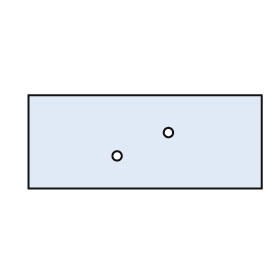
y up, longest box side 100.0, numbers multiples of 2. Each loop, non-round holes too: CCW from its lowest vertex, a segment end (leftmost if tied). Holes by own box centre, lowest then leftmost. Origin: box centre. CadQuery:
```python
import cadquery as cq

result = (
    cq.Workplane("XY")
    .moveTo(-50.0, -20.0)
    .lineTo(50.0, -20.0)
    .lineTo(50.0, 20.0)
    .lineTo(-50.0, 20.0)
    .close()
    .moveTo(-12.0, -6.0)
    .circle(2.0)
    .moveTo(10.0, 4.0)
    .circle(2.0)
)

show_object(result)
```